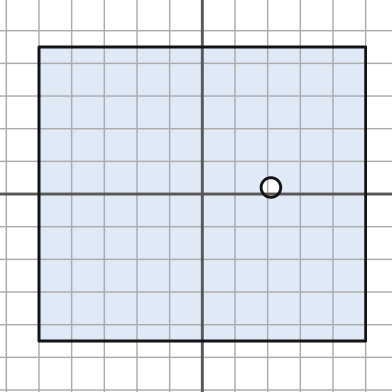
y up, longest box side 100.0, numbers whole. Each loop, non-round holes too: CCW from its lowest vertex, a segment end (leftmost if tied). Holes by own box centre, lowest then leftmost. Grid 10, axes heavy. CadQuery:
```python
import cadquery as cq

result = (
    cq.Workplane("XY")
    .moveTo(-50.0, -45.0)
    .lineTo(50.0, -45.0)
    .lineTo(50.0, 45.0)
    .lineTo(-50.0, 45.0)
    .close()
    .moveTo(21.0, 2.0)
    .circle(3.0)
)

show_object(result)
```